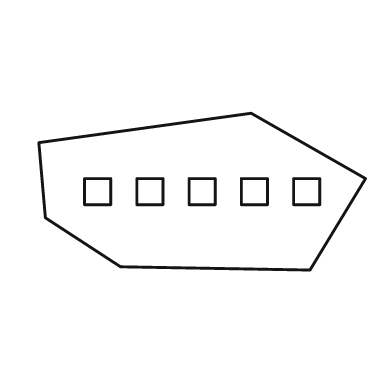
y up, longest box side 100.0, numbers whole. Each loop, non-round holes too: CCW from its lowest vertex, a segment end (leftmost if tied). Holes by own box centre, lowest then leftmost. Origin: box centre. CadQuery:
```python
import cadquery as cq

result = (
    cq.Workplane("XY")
    .moveTo(33.0, -24.0)
    .lineTo(50.0, 4.0)
    .lineTo(15.0, 24.0)
    .lineTo(-50.0, 15.0)
    .lineTo(-48.0, -8.0)
    .lineTo(-25.0, -23.0)
    .close()
    .moveTo(-36.0, -4.0)
    .lineTo(-28.0, -4.0)
    .lineTo(-28.0, 4.0)
    .lineTo(-36.0, 4.0)
    .close()
    .moveTo(-20.0, -4.0)
    .lineTo(-12.0, -4.0)
    .lineTo(-12.0, 4.0)
    .lineTo(-20.0, 4.0)
    .close()
    .moveTo(-4.0, -4.0)
    .lineTo(4.0, -4.0)
    .lineTo(4.0, 4.0)
    .lineTo(-4.0, 4.0)
    .close()
    .moveTo(12.0, -4.0)
    .lineTo(20.0, -4.0)
    .lineTo(20.0, 4.0)
    .lineTo(12.0, 4.0)
    .close()
    .moveTo(28.0, -4.0)
    .lineTo(36.0, -4.0)
    .lineTo(36.0, 4.0)
    .lineTo(28.0, 4.0)
    .close()
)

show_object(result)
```